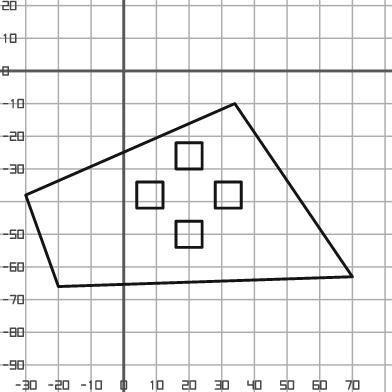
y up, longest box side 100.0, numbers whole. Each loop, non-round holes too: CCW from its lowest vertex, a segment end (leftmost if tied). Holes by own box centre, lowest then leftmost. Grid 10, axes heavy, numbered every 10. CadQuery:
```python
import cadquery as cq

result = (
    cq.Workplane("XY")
    .moveTo(-20.0, -66.0)
    .lineTo(70.0, -63.0)
    .lineTo(34.0, -10.0)
    .lineTo(-30.0, -38.0)
    .close()
    .moveTo(16.0, -54.0)
    .lineTo(24.0, -54.0)
    .lineTo(24.0, -46.0)
    .lineTo(16.0, -46.0)
    .close()
    .moveTo(4.0, -42.0)
    .lineTo(12.0, -42.0)
    .lineTo(12.0, -34.0)
    .lineTo(4.0, -34.0)
    .close()
    .moveTo(28.0, -42.0)
    .lineTo(36.0, -42.0)
    .lineTo(36.0, -34.0)
    .lineTo(28.0, -34.0)
    .close()
    .moveTo(16.0, -30.0)
    .lineTo(24.0, -30.0)
    .lineTo(24.0, -22.0)
    .lineTo(16.0, -22.0)
    .close()
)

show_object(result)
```